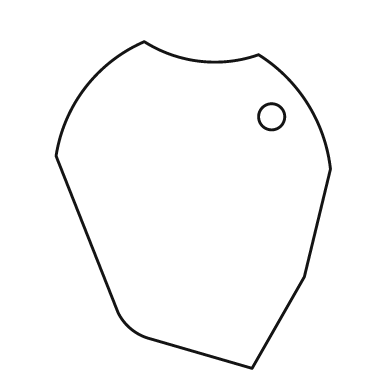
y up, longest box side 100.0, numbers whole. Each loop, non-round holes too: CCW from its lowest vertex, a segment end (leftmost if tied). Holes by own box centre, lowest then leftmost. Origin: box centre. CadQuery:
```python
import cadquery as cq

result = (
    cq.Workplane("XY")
    .moveTo(18.0, -50.0)
    .lineTo(34.0, -22.0)
    .lineTo(42.0, 11.0)
    .threePointArc((35.0, 31.0), (20.0, 46.0))
    .threePointArc((2.0, 44.0), (-15.0, 50.0))
    .threePointArc((-33.0, 36.0), (-42.0, 15.0))
    .lineTo(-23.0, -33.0)
    .threePointArc((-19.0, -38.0), (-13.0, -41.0))
    .close()
    .moveTo(24.0, 27.0)
    .circle(4.0)
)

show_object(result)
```